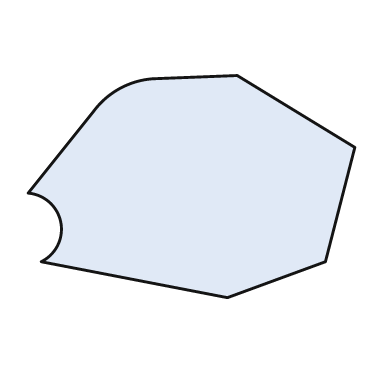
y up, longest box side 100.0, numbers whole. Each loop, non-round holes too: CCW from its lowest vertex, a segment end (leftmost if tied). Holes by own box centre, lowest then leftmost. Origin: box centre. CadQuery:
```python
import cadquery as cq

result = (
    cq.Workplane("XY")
    .moveTo(11.0, -34.0)
    .lineTo(41.0, -23.0)
    .lineTo(50.0, 12.0)
    .lineTo(14.0, 34.0)
    .lineTo(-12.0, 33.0)
    .threePointArc((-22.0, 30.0), (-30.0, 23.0))
    .lineTo(-50.0, -2.0)
    .threePointArc((-40.0, -11.0), (-46.0, -23.0))
    .close()
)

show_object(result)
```